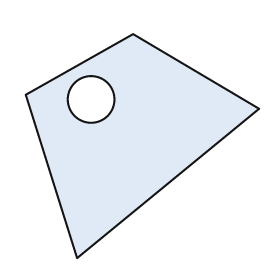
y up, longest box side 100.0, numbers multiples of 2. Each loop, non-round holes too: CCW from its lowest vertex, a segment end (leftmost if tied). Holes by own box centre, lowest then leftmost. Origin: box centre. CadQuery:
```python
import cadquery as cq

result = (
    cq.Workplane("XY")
    .moveTo(-28.0, -48.0)
    .lineTo(50.0, 16.0)
    .lineTo(-4.0, 48.0)
    .lineTo(-50.0, 22.0)
    .close()
    .moveTo(-22.0, 20.0)
    .circle(10.0)
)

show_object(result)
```